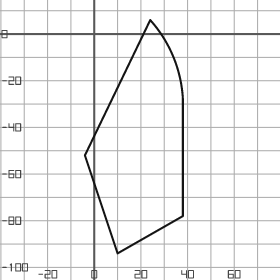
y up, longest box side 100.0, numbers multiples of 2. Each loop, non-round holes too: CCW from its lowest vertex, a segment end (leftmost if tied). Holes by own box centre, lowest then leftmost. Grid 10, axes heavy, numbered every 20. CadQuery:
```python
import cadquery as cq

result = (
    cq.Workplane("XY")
    .moveTo(10.0, -94.0)
    .lineTo(38.0, -78.0)
    .lineTo(38.0, -28.0)
    .threePointArc((34.0, -10.0), (24.0, 6.0))
    .lineTo(-4.0, -52.0)
    .close()
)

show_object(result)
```